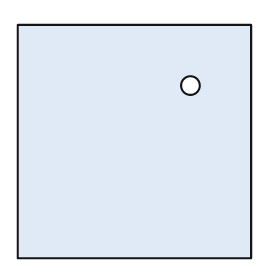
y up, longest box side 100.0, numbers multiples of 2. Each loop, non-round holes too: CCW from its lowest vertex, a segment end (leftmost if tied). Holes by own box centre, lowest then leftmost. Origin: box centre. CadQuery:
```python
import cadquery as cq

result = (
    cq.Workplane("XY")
    .moveTo(-50.0, -50.0)
    .lineTo(50.0, -50.0)
    .lineTo(50.0, 50.0)
    .lineTo(-50.0, 50.0)
    .close()
    .moveTo(24.0, 24.0)
    .circle(4.0)
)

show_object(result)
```